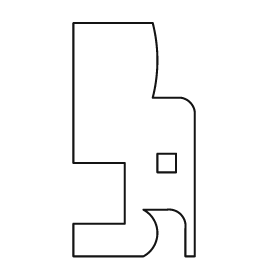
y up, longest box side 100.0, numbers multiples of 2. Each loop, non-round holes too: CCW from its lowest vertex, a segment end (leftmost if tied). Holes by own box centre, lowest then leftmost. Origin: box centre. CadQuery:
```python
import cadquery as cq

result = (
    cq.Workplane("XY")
    .moveTo(-26.0, -50.0)
    .lineTo(4.0, -50.0)
    .threePointArc((10.0, -40.0), (4.0, -30.0))
    .lineTo(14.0, -30.0)
    .threePointArc((20.0, -32.0), (22.0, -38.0))
    .lineTo(22.0, -50.0)
    .lineTo(26.0, -50.0)
    .lineTo(26.0, 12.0)
    .threePointArc((24.0, 16.0), (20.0, 18.0))
    .lineTo(8.0, 18.0)
    .threePointArc((10.0, 34.0), (8.0, 50.0))
    .lineTo(-26.0, 50.0)
    .lineTo(-26.0, -10.0)
    .lineTo(-4.0, -10.0)
    .lineTo(-4.0, -36.0)
    .lineTo(-26.0, -36.0)
    .close()
    .moveTo(10.0, -14.0)
    .lineTo(18.0, -14.0)
    .lineTo(18.0, -6.0)
    .lineTo(10.0, -6.0)
    .close()
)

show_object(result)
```